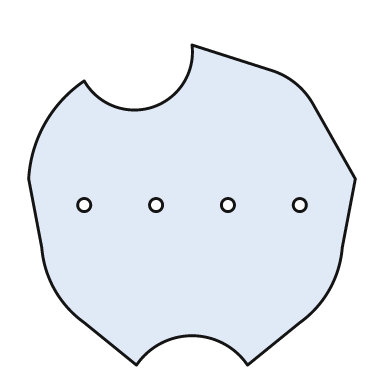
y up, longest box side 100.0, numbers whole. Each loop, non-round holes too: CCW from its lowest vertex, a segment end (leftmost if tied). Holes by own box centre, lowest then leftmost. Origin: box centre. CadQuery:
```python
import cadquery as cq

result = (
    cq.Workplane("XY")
    .moveTo(-17.0, -49.0)
    .threePointArc((0.0, -40.0), (17.0, -49.0))
    .lineTo(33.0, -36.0)
    .threePointArc((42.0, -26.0), (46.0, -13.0))
    .lineTo(50.0, 8.0)
    .lineTo(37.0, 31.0)
    .threePointArc((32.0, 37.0), (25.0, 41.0))
    .lineTo(0.0, 49.0)
    .threePointArc((-12.0, 30.0), (-33.0, 38.0))
    .threePointArc((-45.0, 25.0), (-50.0, 8.0))
    .lineTo(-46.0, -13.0)
    .threePointArc((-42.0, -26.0), (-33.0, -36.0))
    .close()
    .moveTo(-33.0, 0.0)
    .circle(2.0)
    .moveTo(-11.0, 0.0)
    .circle(2.0)
    .moveTo(11.0, 0.0)
    .circle(2.0)
    .moveTo(33.0, 0.0)
    .circle(2.0)
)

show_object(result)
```